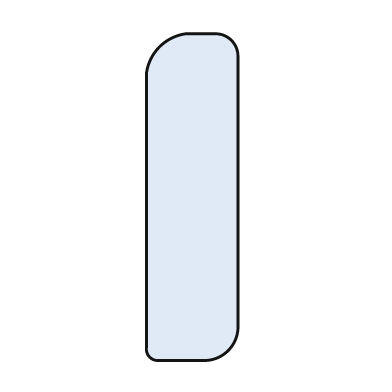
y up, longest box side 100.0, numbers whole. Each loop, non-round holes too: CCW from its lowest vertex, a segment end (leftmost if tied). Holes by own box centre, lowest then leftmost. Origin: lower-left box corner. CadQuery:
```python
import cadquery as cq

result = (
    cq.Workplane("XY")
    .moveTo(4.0, 0.0)
    .lineTo(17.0, 0.0)
    .threePointArc((25.0, 3.0), (28.0, 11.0))
    .lineTo(28.0, 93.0)
    .threePointArc((26.0, 98.0), (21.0, 100.0))
    .lineTo(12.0, 100.0)
    .threePointArc((4.0, 96.0), (0.0, 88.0))
    .lineTo(0.0, 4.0)
    .threePointArc((1.0, 1.0), (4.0, 0.0))
    .close()
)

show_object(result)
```